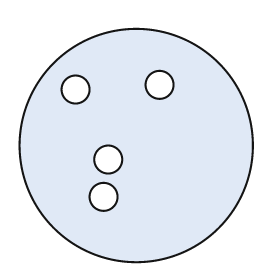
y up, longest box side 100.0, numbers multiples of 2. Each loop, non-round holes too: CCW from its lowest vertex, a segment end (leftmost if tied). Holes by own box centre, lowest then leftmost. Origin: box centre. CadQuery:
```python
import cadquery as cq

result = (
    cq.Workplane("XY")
    .moveTo(0.0, 0.0)
    .circle(50.0)
    .moveTo(-14.0, -22.0)
    .circle(6.0)
    .moveTo(-12.0, -6.0)
    .circle(6.0)
    .moveTo(-26.0, 24.0)
    .circle(6.0)
    .moveTo(10.0, 26.0)
    .circle(6.0)
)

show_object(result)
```